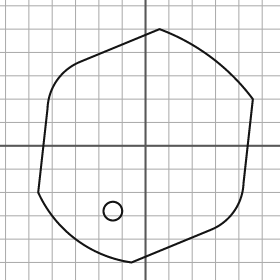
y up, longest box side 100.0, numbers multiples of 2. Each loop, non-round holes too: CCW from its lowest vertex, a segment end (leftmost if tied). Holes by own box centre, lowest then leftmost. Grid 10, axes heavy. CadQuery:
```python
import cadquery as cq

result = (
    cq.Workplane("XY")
    .moveTo(-6.0, -50.0)
    .lineTo(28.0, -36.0)
    .threePointArc((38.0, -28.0), (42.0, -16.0))
    .lineTo(46.0, 20.0)
    .threePointArc((28.0, 38.0), (6.0, 50.0))
    .lineTo(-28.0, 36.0)
    .threePointArc((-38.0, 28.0), (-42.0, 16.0))
    .lineTo(-46.0, -20.0)
    .threePointArc((-30.0, -40.0), (-6.0, -50.0))
    .close()
    .moveTo(-14.0, -28.0)
    .circle(4.0)
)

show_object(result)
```